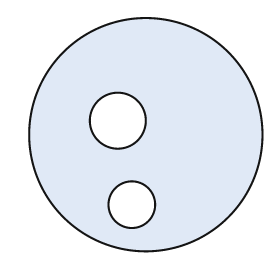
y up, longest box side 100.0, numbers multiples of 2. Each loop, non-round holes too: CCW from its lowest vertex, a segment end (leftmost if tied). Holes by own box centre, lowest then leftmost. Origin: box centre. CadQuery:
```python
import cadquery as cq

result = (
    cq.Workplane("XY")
    .moveTo(0.0, 0.0)
    .circle(50.0)
    .moveTo(-6.0, -30.0)
    .circle(10.0)
    .moveTo(-12.0, 6.0)
    .circle(12.0)
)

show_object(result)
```